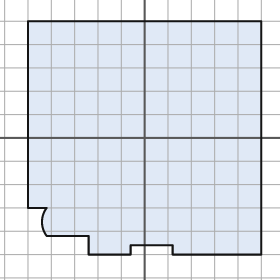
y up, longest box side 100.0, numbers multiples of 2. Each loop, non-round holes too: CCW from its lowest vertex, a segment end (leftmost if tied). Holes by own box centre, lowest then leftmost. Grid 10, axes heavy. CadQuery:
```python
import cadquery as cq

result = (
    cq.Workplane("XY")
    .moveTo(-24.0, -50.0)
    .lineTo(-6.0, -50.0)
    .lineTo(-6.0, -46.0)
    .lineTo(12.0, -46.0)
    .lineTo(12.0, -50.0)
    .lineTo(50.0, -50.0)
    .lineTo(50.0, 50.0)
    .lineTo(-50.0, 50.0)
    .lineTo(-50.0, -30.0)
    .lineTo(-42.0, -30.0)
    .threePointArc((-44.0, -36.0), (-42.0, -42.0))
    .lineTo(-24.0, -42.0)
    .close()
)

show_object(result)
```